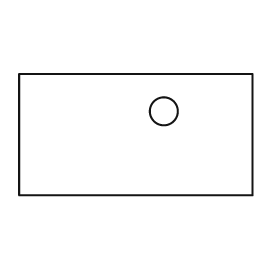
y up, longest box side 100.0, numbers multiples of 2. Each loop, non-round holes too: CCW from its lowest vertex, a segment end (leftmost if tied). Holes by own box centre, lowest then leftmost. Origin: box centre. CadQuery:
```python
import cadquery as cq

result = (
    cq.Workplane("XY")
    .moveTo(-50.0, -26.0)
    .lineTo(50.0, -26.0)
    .lineTo(50.0, 26.0)
    .lineTo(-50.0, 26.0)
    .close()
    .moveTo(12.0, 10.0)
    .circle(6.0)
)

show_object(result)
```